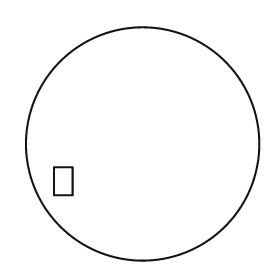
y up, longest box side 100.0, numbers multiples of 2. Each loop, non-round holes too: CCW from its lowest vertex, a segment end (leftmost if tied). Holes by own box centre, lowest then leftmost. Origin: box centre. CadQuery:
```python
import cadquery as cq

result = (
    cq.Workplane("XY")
    .moveTo(0.0, 0.0)
    .circle(50.0)
    .moveTo(-38.0, -22.0)
    .lineTo(-30.0, -22.0)
    .lineTo(-30.0, -10.0)
    .lineTo(-38.0, -10.0)
    .close()
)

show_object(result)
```